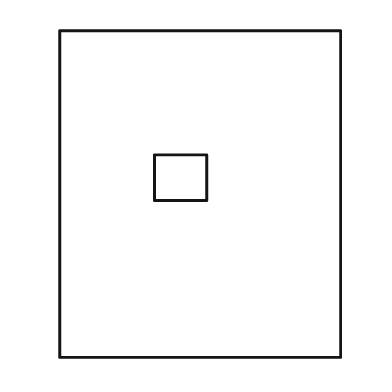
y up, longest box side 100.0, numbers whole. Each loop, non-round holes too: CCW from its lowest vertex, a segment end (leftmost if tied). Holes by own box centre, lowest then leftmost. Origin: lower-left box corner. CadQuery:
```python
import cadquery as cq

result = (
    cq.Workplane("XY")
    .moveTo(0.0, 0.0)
    .lineTo(86.0, 0.0)
    .lineTo(86.0, 100.0)
    .lineTo(0.0, 100.0)
    .close()
    .moveTo(29.0, 48.0)
    .lineTo(45.0, 48.0)
    .lineTo(45.0, 62.0)
    .lineTo(29.0, 62.0)
    .close()
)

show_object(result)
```